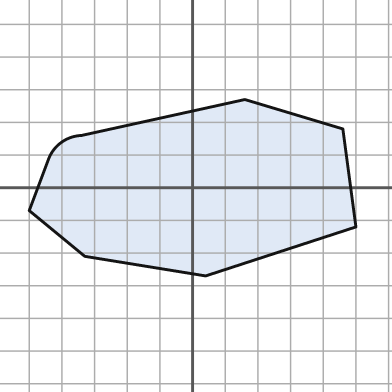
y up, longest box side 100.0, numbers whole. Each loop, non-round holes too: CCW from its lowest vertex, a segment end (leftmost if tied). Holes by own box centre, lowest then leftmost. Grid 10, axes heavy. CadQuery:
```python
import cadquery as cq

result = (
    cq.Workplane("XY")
    .moveTo(4.0, -27.0)
    .lineTo(50.0, -12.0)
    .lineTo(46.0, 18.0)
    .lineTo(16.0, 27.0)
    .lineTo(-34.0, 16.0)
    .threePointArc((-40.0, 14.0), (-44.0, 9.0))
    .lineTo(-50.0, -7.0)
    .lineTo(-33.0, -21.0)
    .close()
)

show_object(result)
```